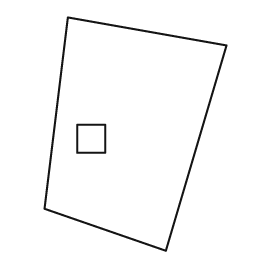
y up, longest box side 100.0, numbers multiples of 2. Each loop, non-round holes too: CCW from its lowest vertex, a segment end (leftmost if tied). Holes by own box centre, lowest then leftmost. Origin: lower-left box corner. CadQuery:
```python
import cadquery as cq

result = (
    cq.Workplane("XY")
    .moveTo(52.0, 0.0)
    .lineTo(78.0, 88.0)
    .lineTo(10.0, 100.0)
    .lineTo(0.0, 18.0)
    .close()
    .moveTo(14.0, 42.0)
    .lineTo(26.0, 42.0)
    .lineTo(26.0, 54.0)
    .lineTo(14.0, 54.0)
    .close()
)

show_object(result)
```